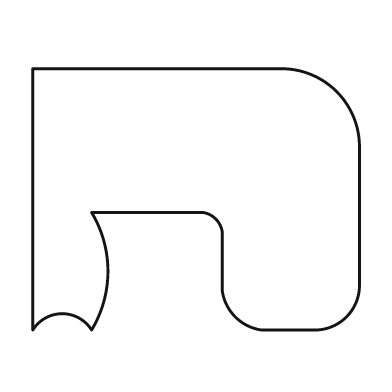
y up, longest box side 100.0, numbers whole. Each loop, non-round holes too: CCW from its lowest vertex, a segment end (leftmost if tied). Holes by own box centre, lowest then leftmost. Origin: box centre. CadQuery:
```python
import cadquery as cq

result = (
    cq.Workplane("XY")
    .moveTo(-50.0, -40.0)
    .threePointArc((-41.0, -35.0), (-32.0, -40.0))
    .threePointArc((-27.0, -22.0), (-32.0, -4.0))
    .lineTo(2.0, -4.0)
    .threePointArc((6.0, -6.0), (8.0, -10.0))
    .lineTo(8.0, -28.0)
    .threePointArc((12.0, -36.0), (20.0, -40.0))
    .lineTo(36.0, -40.0)
    .threePointArc((46.0, -36.0), (50.0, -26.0))
    .lineTo(50.0, 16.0)
    .threePointArc((43.0, 33.0), (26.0, 40.0))
    .lineTo(-50.0, 40.0)
    .close()
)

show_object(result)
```